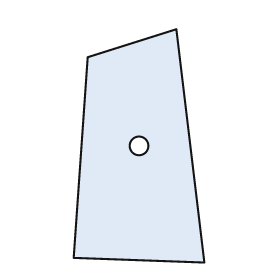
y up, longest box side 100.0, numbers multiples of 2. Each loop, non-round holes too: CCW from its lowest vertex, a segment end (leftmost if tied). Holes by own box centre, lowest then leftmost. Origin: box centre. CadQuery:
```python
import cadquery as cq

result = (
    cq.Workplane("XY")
    .moveTo(28.0, -50.0)
    .lineTo(16.0, 50.0)
    .lineTo(-22.0, 38.0)
    .lineTo(-28.0, -48.0)
    .close()
    .moveTo(0.0, 0.0)
    .circle(4.0)
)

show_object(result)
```